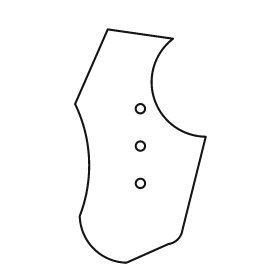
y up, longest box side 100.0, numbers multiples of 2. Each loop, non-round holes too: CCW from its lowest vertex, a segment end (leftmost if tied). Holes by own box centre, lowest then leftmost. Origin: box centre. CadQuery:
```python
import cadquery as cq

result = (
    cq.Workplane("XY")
    .moveTo(-6.0, -50.0)
    .lineTo(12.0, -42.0)
    .threePointArc((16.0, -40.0), (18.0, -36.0))
    .lineTo(28.0, 4.0)
    .threePointArc((6.0, 20.0), (14.0, 46.0))
    .lineTo(-14.0, 50.0)
    .lineTo(-28.0, 18.0)
    .threePointArc((-22.0, -6.0), (-26.0, -30.0))
    .threePointArc((-20.0, -44.0), (-6.0, -50.0))
    .close()
    .moveTo(0.0, -16.0)
    .circle(2.0)
    .moveTo(0.0, 0.0)
    .circle(2.0)
    .moveTo(0.0, 16.0)
    .circle(2.0)
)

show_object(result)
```